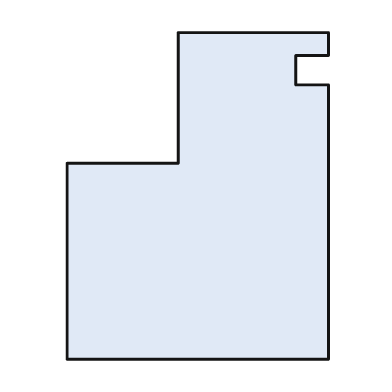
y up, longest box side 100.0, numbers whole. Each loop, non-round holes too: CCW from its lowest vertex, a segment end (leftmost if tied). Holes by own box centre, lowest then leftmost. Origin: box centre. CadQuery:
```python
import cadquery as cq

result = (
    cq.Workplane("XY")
    .moveTo(-40.0, -50.0)
    .lineTo(40.0, -50.0)
    .lineTo(40.0, 34.0)
    .lineTo(30.0, 34.0)
    .lineTo(30.0, 43.0)
    .lineTo(40.0, 43.0)
    .lineTo(40.0, 50.0)
    .lineTo(-6.0, 50.0)
    .lineTo(-6.0, 10.0)
    .lineTo(-40.0, 10.0)
    .close()
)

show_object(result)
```